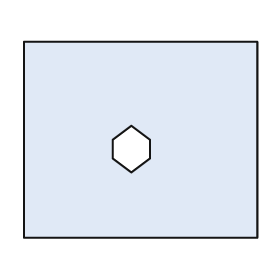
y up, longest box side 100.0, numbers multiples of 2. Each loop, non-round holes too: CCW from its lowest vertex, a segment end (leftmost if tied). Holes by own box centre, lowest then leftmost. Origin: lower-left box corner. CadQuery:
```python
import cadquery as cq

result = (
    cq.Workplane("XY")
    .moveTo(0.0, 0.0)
    .lineTo(100.0, 0.0)
    .lineTo(100.0, 84.0)
    .lineTo(0.0, 84.0)
    .close()
    .moveTo(46.0, 28.0)
    .lineTo(54.0, 34.0)
    .lineTo(54.0, 42.0)
    .lineTo(46.0, 48.0)
    .lineTo(38.0, 42.0)
    .lineTo(38.0, 34.0)
    .close()
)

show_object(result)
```